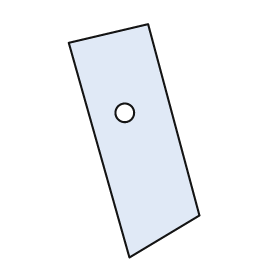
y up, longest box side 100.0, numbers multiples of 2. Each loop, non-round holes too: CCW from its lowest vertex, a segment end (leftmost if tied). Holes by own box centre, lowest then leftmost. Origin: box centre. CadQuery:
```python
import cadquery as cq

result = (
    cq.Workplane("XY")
    .moveTo(-2.0, -50.0)
    .lineTo(28.0, -32.0)
    .lineTo(6.0, 50.0)
    .lineTo(-28.0, 42.0)
    .close()
    .moveTo(-4.0, 12.0)
    .circle(4.0)
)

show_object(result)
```